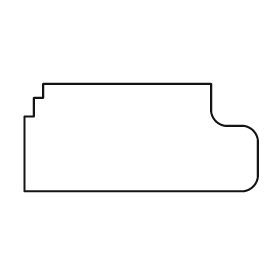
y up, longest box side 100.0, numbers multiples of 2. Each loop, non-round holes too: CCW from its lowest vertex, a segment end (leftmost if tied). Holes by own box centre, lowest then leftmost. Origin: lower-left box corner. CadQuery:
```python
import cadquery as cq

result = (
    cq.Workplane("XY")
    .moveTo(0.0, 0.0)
    .lineTo(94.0, 0.0)
    .threePointArc((98.0, 2.0), (100.0, 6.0))
    .lineTo(100.0, 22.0)
    .threePointArc((98.0, 26.0), (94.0, 28.0))
    .lineTo(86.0, 28.0)
    .threePointArc((82.0, 30.0), (80.0, 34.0))
    .lineTo(80.0, 46.0)
    .lineTo(8.0, 46.0)
    .lineTo(8.0, 40.0)
    .lineTo(4.0, 40.0)
    .lineTo(4.0, 32.0)
    .lineTo(0.0, 32.0)
    .close()
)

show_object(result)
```